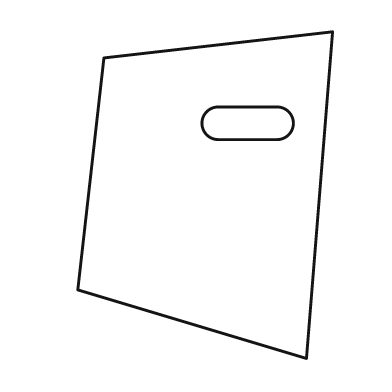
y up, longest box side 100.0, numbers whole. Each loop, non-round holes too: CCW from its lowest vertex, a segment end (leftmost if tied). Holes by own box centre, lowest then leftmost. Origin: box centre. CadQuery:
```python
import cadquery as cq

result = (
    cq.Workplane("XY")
    .moveTo(31.0, -50.0)
    .lineTo(39.0, 50.0)
    .lineTo(-31.0, 42.0)
    .lineTo(-39.0, -29.0)
    .close()
    .moveTo(4.0, 17.0)
    .lineTo(22.0, 17.0)
    .threePointArc((27.0, 22.0), (22.0, 27.0))
    .lineTo(4.0, 27.0)
    .threePointArc((-1.0, 22.0), (4.0, 17.0))
    .close()
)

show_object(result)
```